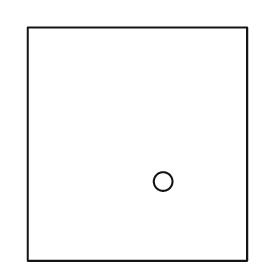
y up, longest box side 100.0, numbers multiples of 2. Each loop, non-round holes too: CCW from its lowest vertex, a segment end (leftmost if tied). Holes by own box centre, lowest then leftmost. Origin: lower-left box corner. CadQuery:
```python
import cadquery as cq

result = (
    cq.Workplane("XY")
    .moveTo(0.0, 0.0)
    .lineTo(94.0, 0.0)
    .lineTo(94.0, 100.0)
    .lineTo(0.0, 100.0)
    .close()
    .moveTo(58.0, 34.0)
    .circle(4.0)
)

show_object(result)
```